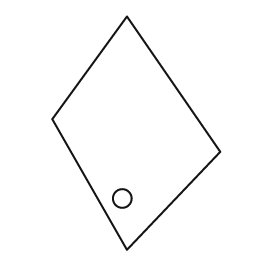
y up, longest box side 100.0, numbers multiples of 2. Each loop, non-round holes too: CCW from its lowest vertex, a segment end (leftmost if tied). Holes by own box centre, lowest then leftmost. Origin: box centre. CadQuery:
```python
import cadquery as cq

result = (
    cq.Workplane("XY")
    .moveTo(-4.0, -50.0)
    .lineTo(36.0, -8.0)
    .lineTo(-4.0, 50.0)
    .lineTo(-36.0, 6.0)
    .close()
    .moveTo(-6.0, -28.0)
    .circle(4.0)
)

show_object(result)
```